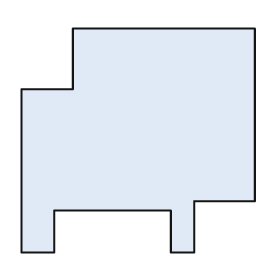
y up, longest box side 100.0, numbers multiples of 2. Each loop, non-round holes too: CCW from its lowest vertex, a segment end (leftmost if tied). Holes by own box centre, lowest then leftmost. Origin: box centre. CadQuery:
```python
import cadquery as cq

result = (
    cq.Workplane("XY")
    .moveTo(-50.0, -48.0)
    .lineTo(-36.0, -48.0)
    .lineTo(-36.0, -30.0)
    .lineTo(14.0, -30.0)
    .lineTo(14.0, -48.0)
    .lineTo(24.0, -48.0)
    .lineTo(24.0, -26.0)
    .lineTo(50.0, -26.0)
    .lineTo(50.0, 48.0)
    .lineTo(-28.0, 48.0)
    .lineTo(-28.0, 22.0)
    .lineTo(-50.0, 22.0)
    .close()
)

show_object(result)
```